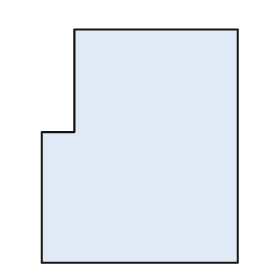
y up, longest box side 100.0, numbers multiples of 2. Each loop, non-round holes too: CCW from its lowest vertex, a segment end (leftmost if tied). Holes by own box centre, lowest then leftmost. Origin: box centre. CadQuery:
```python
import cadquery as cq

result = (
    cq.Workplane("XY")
    .moveTo(-42.0, -50.0)
    .lineTo(42.0, -50.0)
    .lineTo(42.0, 50.0)
    .lineTo(-28.0, 50.0)
    .lineTo(-28.0, 6.0)
    .lineTo(-42.0, 6.0)
    .close()
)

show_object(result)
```